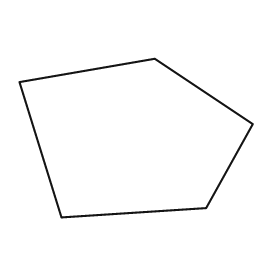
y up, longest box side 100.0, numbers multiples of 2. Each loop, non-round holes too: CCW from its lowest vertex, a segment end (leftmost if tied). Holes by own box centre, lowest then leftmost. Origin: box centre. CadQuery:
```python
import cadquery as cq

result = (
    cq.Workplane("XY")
    .moveTo(-32.0, -34.0)
    .lineTo(30.0, -30.0)
    .lineTo(50.0, 6.0)
    .lineTo(8.0, 34.0)
    .lineTo(-50.0, 24.0)
    .close()
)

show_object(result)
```